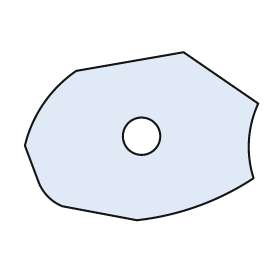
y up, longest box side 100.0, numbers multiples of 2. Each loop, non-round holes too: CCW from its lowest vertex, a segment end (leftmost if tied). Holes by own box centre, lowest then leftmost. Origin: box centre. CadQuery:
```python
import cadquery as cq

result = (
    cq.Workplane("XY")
    .moveTo(-2.0, -36.0)
    .threePointArc((24.0, -30.0), (48.0, -18.0))
    .threePointArc((46.0, -2.0), (50.0, 14.0))
    .lineTo(18.0, 36.0)
    .lineTo(-28.0, 28.0)
    .threePointArc((-42.0, 14.0), (-50.0, -4.0))
    .lineTo(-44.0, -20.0)
    .threePointArc((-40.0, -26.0), (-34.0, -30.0))
    .close()
    .moveTo(0.0, 0.0)
    .circle(8.0)
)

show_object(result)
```